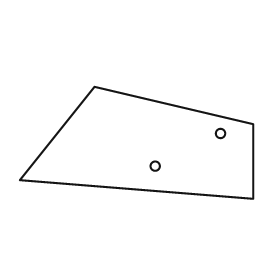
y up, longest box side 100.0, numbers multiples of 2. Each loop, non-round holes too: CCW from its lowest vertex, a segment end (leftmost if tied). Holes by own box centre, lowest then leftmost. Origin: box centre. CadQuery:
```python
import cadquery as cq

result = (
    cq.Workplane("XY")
    .moveTo(50.0, -24.0)
    .lineTo(50.0, 8.0)
    .lineTo(-18.0, 24.0)
    .lineTo(-50.0, -16.0)
    .close()
    .moveTo(8.0, -10.0)
    .circle(2.0)
    .moveTo(36.0, 4.0)
    .circle(2.0)
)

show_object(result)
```